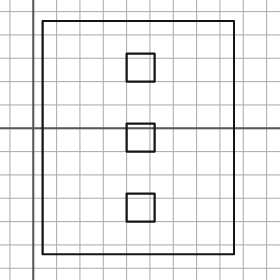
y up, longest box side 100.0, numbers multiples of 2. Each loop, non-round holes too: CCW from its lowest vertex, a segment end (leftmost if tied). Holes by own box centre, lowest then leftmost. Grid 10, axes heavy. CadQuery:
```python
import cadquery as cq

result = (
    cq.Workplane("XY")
    .moveTo(4.0, -54.0)
    .lineTo(86.0, -54.0)
    .lineTo(86.0, 46.0)
    .lineTo(4.0, 46.0)
    .close()
    .moveTo(40.0, -40.0)
    .lineTo(52.0, -40.0)
    .lineTo(52.0, -28.0)
    .lineTo(40.0, -28.0)
    .close()
    .moveTo(40.0, -10.0)
    .lineTo(52.0, -10.0)
    .lineTo(52.0, 2.0)
    .lineTo(40.0, 2.0)
    .close()
    .moveTo(40.0, 20.0)
    .lineTo(52.0, 20.0)
    .lineTo(52.0, 32.0)
    .lineTo(40.0, 32.0)
    .close()
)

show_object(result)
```